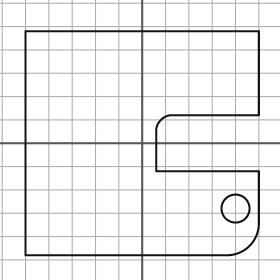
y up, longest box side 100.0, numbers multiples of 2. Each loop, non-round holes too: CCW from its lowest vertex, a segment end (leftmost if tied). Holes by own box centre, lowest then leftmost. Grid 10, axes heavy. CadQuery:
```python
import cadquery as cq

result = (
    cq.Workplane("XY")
    .moveTo(-50.0, -48.0)
    .lineTo(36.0, -48.0)
    .threePointArc((46.0, -44.0), (50.0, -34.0))
    .lineTo(50.0, -12.0)
    .lineTo(6.0, -12.0)
    .lineTo(6.0, 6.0)
    .threePointArc((8.0, 10.0), (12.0, 12.0))
    .lineTo(50.0, 12.0)
    .lineTo(50.0, 48.0)
    .lineTo(-50.0, 48.0)
    .close()
    .moveTo(40.0, -28.0)
    .circle(6.0)
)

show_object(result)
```